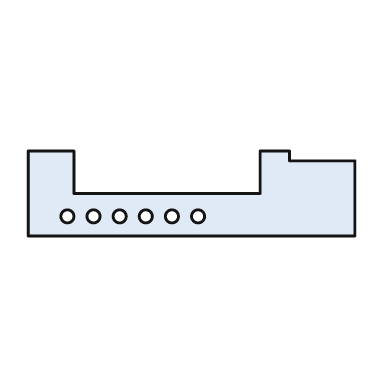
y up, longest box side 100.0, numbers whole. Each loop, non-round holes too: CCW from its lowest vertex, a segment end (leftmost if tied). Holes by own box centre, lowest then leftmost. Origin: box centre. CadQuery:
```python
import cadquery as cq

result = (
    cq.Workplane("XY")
    .moveTo(-50.0, -13.0)
    .lineTo(50.0, -13.0)
    .lineTo(50.0, 10.0)
    .lineTo(30.0, 10.0)
    .lineTo(30.0, 13.0)
    .lineTo(21.0, 13.0)
    .lineTo(21.0, 0.0)
    .lineTo(-36.0, 0.0)
    .lineTo(-36.0, 13.0)
    .lineTo(-50.0, 13.0)
    .close()
    .moveTo(-38.0, -7.0)
    .circle(2.0)
    .moveTo(-30.0, -7.0)
    .circle(2.0)
    .moveTo(-22.0, -7.0)
    .circle(2.0)
    .moveTo(-14.0, -7.0)
    .circle(2.0)
    .moveTo(-6.0, -7.0)
    .circle(2.0)
    .moveTo(2.0, -7.0)
    .circle(2.0)
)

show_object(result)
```